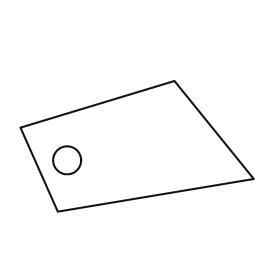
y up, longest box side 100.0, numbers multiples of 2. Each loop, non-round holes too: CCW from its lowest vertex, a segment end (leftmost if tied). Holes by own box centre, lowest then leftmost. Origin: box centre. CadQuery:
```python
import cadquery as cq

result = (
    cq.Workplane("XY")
    .moveTo(-34.0, -28.0)
    .lineTo(50.0, -14.0)
    .lineTo(16.0, 28.0)
    .lineTo(-50.0, 8.0)
    .close()
    .moveTo(-30.0, -6.0)
    .circle(6.0)
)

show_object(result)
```